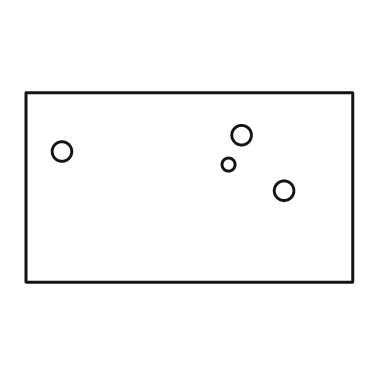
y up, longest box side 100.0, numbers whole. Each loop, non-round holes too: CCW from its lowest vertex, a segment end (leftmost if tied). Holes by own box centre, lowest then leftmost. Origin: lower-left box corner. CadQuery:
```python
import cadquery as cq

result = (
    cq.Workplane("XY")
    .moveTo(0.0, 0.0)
    .lineTo(100.0, 0.0)
    .lineTo(100.0, 58.0)
    .lineTo(0.0, 58.0)
    .close()
    .moveTo(79.0, 28.0)
    .circle(3.0)
    .moveTo(62.0, 36.0)
    .circle(2.0)
    .moveTo(11.0, 40.0)
    .circle(3.0)
    .moveTo(66.0, 45.0)
    .circle(3.0)
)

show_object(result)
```